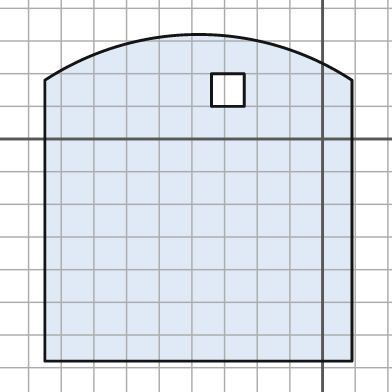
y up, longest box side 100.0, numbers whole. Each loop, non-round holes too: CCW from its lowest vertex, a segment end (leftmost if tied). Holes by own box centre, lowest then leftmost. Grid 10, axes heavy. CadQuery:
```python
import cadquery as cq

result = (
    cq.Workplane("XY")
    .moveTo(-85.0, -68.0)
    .lineTo(9.0, -68.0)
    .lineTo(9.0, 18.0)
    .threePointArc((-38.0, 32.0), (-85.0, 18.0))
    .close()
    .moveTo(-34.0, 10.0)
    .lineTo(-24.0, 10.0)
    .lineTo(-24.0, 20.0)
    .lineTo(-34.0, 20.0)
    .close()
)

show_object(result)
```